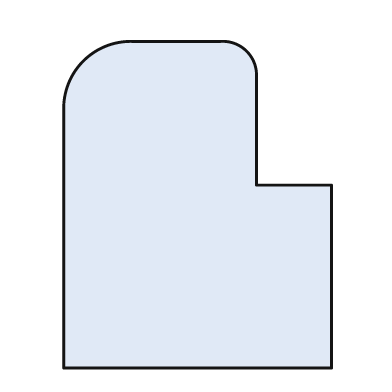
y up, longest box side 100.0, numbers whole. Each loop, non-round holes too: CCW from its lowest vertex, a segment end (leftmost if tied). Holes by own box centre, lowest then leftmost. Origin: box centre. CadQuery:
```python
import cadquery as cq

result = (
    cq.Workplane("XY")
    .moveTo(-41.0, -50.0)
    .lineTo(41.0, -50.0)
    .lineTo(41.0, 6.0)
    .lineTo(18.0, 6.0)
    .lineTo(18.0, 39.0)
    .threePointArc((15.0, 47.0), (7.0, 50.0))
    .lineTo(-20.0, 50.0)
    .threePointArc((-35.0, 44.0), (-41.0, 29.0))
    .close()
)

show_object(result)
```